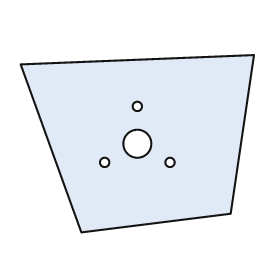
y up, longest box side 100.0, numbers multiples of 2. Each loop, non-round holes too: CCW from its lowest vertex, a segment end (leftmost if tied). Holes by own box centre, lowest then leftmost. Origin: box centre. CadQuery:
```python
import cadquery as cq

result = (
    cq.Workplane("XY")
    .moveTo(-24.0, -38.0)
    .lineTo(40.0, -30.0)
    .lineTo(50.0, 38.0)
    .lineTo(-50.0, 34.0)
    .close()
    .moveTo(-14.0, -8.0)
    .circle(2.0)
    .moveTo(14.0, -8.0)
    .circle(2.0)
    .moveTo(0.0, 0.0)
    .circle(6.0)
    .moveTo(0.0, 16.0)
    .circle(2.0)
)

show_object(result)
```